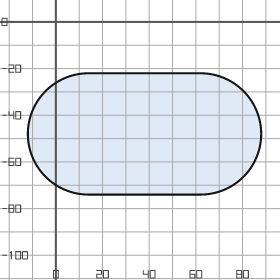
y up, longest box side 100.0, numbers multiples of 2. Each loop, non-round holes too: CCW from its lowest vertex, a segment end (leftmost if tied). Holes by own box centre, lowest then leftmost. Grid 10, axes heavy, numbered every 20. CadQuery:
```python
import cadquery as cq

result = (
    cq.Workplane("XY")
    .moveTo(14.0, -74.0)
    .lineTo(62.0, -74.0)
    .threePointArc((88.0, -48.0), (62.0, -22.0))
    .lineTo(14.0, -22.0)
    .threePointArc((-12.0, -48.0), (14.0, -74.0))
    .close()
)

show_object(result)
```